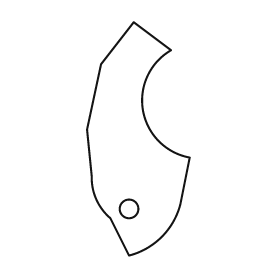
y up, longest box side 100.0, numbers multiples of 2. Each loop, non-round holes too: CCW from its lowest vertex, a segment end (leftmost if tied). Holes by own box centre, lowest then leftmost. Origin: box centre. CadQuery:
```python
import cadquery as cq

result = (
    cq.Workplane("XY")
    .moveTo(-4.0, -50.0)
    .threePointArc((10.0, -42.0), (18.0, -28.0))
    .lineTo(22.0, -8.0)
    .threePointArc((2.0, 12.0), (14.0, 38.0))
    .lineTo(-2.0, 50.0)
    .lineTo(-16.0, 32.0)
    .lineTo(-22.0, 4.0)
    .lineTo(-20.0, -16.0)
    .threePointArc((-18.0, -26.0), (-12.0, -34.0))
    .close()
    .moveTo(-4.0, -30.0)
    .circle(4.0)
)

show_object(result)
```